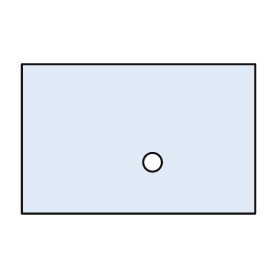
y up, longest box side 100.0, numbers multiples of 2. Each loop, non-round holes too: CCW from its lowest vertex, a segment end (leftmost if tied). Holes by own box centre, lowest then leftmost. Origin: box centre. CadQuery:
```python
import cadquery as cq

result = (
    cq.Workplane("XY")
    .moveTo(-50.0, -32.0)
    .lineTo(50.0, -32.0)
    .lineTo(50.0, 32.0)
    .lineTo(-50.0, 32.0)
    .close()
    .moveTo(6.0, -10.0)
    .circle(4.0)
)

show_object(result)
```